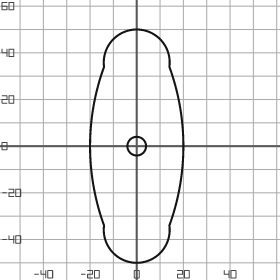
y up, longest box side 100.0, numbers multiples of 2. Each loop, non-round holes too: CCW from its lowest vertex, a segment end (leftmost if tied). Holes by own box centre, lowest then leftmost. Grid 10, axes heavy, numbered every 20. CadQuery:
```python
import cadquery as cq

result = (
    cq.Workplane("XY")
    .moveTo(-14.0, -34.0)
    .threePointArc((0.0, -50.0), (14.0, -34.0))
    .threePointArc((20.0, 0.0), (14.0, 34.0))
    .threePointArc((0.0, 50.0), (-14.0, 34.0))
    .threePointArc((-20.0, 0.0), (-14.0, -34.0))
    .close()
    .moveTo(0.0, 0.0)
    .circle(4.0)
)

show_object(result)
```